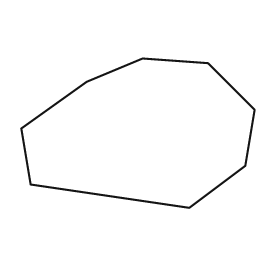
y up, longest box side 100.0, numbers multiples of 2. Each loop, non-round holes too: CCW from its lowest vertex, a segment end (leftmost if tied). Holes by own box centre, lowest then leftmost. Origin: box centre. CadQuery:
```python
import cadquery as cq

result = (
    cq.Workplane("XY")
    .moveTo(22.0, -32.0)
    .lineTo(46.0, -14.0)
    .lineTo(50.0, 10.0)
    .lineTo(30.0, 30.0)
    .lineTo(2.0, 32.0)
    .lineTo(-22.0, 22.0)
    .lineTo(-50.0, 2.0)
    .lineTo(-46.0, -22.0)
    .close()
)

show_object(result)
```